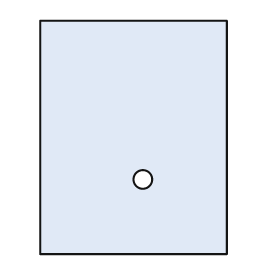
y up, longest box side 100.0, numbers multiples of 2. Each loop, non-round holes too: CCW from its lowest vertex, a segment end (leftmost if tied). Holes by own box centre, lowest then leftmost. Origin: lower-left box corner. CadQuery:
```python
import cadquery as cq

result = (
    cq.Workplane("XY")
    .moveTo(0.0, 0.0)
    .lineTo(80.0, 0.0)
    .lineTo(80.0, 100.0)
    .lineTo(0.0, 100.0)
    .close()
    .moveTo(44.0, 32.0)
    .circle(4.0)
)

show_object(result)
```